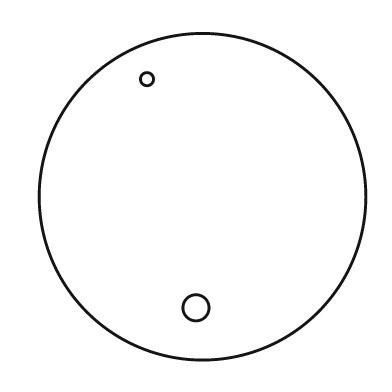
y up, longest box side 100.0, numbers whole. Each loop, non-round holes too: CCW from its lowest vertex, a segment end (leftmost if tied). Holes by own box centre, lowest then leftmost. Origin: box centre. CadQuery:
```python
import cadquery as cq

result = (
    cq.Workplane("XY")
    .moveTo(0.0, 0.0)
    .circle(50.0)
    .moveTo(-2.0, -34.0)
    .circle(4.0)
    .moveTo(-17.0, 36.0)
    .circle(2.0)
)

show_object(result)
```